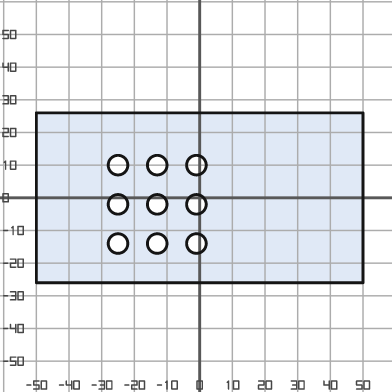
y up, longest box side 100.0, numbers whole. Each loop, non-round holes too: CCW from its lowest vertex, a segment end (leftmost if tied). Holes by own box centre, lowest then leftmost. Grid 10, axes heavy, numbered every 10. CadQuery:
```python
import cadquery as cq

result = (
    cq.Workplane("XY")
    .moveTo(-50.0, -26.0)
    .lineTo(50.0, -26.0)
    .lineTo(50.0, 26.0)
    .lineTo(-50.0, 26.0)
    .close()
    .moveTo(-25.0, -14.0)
    .circle(3.0)
    .moveTo(-13.0, -14.0)
    .circle(3.0)
    .moveTo(-1.0, -14.0)
    .circle(3.0)
    .moveTo(-25.0, -2.0)
    .circle(3.0)
    .moveTo(-13.0, -2.0)
    .circle(3.0)
    .moveTo(-1.0, -2.0)
    .circle(3.0)
    .moveTo(-25.0, 10.0)
    .circle(3.0)
    .moveTo(-13.0, 10.0)
    .circle(3.0)
    .moveTo(-1.0, 10.0)
    .circle(3.0)
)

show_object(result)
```